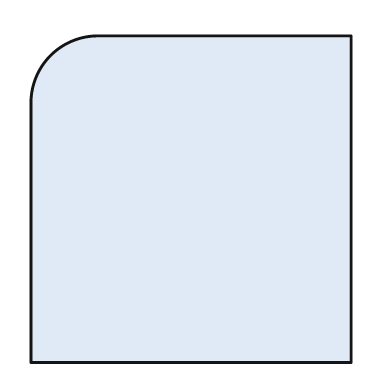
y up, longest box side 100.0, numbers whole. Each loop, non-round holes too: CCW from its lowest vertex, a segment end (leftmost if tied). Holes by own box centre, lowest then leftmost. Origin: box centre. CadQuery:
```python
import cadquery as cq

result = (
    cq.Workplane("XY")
    .moveTo(-49.0, -50.0)
    .lineTo(49.0, -50.0)
    .lineTo(49.0, 50.0)
    .lineTo(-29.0, 50.0)
    .threePointArc((-43.0, 44.0), (-49.0, 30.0))
    .close()
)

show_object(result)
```